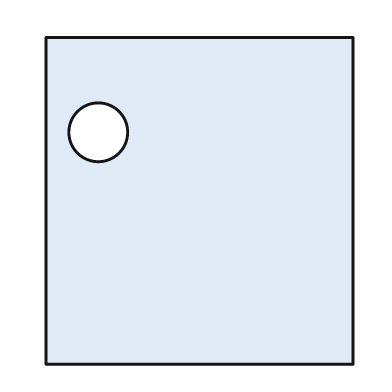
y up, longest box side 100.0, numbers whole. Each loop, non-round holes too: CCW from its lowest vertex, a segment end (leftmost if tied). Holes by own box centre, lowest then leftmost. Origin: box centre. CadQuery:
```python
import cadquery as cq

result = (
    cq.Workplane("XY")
    .moveTo(-47.0, -50.0)
    .lineTo(47.0, -50.0)
    .lineTo(47.0, 50.0)
    .lineTo(-47.0, 50.0)
    .close()
    .moveTo(-31.0, 21.0)
    .circle(9.0)
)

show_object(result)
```